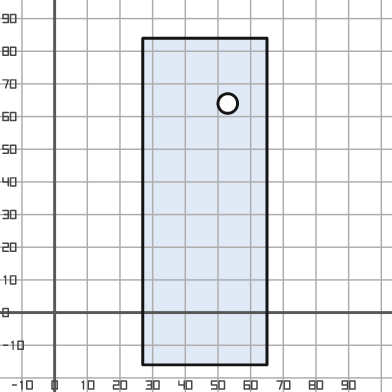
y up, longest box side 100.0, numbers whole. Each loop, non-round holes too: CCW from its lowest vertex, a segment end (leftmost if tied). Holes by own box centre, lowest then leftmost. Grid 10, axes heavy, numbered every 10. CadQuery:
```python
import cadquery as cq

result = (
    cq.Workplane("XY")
    .moveTo(27.0, -16.0)
    .lineTo(65.0, -16.0)
    .lineTo(65.0, 84.0)
    .lineTo(27.0, 84.0)
    .close()
    .moveTo(53.0, 64.0)
    .circle(3.0)
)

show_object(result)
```